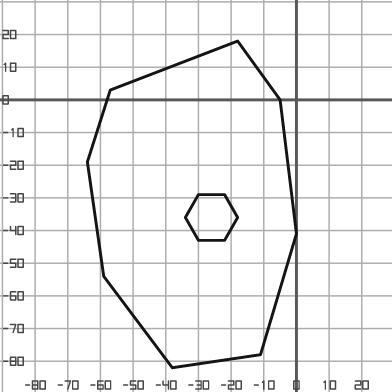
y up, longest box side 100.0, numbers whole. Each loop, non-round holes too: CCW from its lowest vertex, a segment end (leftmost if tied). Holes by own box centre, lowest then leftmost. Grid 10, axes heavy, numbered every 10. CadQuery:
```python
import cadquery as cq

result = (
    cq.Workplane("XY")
    .moveTo(-38.0, -82.0)
    .lineTo(-11.0, -78.0)
    .lineTo(0.0, -41.0)
    .lineTo(-5.0, 0.0)
    .lineTo(-18.0, 18.0)
    .lineTo(-57.0, 3.0)
    .lineTo(-64.0, -19.0)
    .lineTo(-59.0, -54.0)
    .close()
    .moveTo(-30.0, -43.0)
    .lineTo(-22.0, -43.0)
    .lineTo(-18.0, -36.0)
    .lineTo(-22.0, -29.0)
    .lineTo(-30.0, -29.0)
    .lineTo(-34.0, -36.0)
    .close()
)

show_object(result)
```